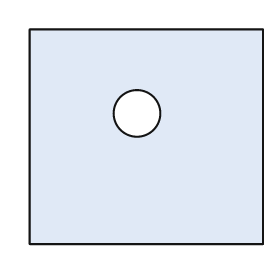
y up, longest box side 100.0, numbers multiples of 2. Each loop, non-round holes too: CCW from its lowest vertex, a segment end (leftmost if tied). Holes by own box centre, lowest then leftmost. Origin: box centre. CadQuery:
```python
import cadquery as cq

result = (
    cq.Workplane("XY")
    .moveTo(-50.0, -46.0)
    .lineTo(50.0, -46.0)
    .lineTo(50.0, 46.0)
    .lineTo(-50.0, 46.0)
    .close()
    .moveTo(-4.0, 10.0)
    .circle(10.0)
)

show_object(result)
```